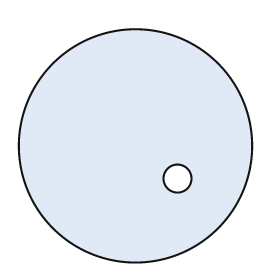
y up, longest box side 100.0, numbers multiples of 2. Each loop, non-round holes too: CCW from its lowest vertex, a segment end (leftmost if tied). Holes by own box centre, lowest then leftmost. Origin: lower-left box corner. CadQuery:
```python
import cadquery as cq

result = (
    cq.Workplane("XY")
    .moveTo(50.0, 50.0)
    .circle(50.0)
    .moveTo(68.0, 36.0)
    .circle(6.0)
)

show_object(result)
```